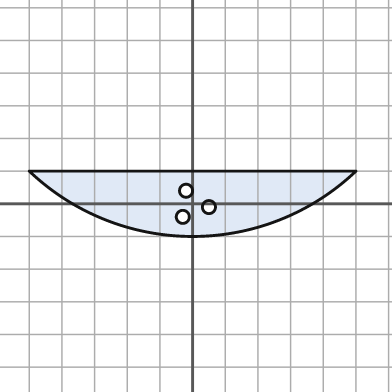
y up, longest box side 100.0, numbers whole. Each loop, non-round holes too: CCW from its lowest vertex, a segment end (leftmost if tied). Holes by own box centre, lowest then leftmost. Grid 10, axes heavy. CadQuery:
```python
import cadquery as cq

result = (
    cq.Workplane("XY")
    .moveTo(-50.0, 10.0)
    .threePointArc((0.0, -10.0), (50.0, 10.0))
    .close()
    .moveTo(-3.0, -4.0)
    .circle(2.0)
    .moveTo(5.0, -1.0)
    .circle(2.0)
    .moveTo(-2.0, 4.0)
    .circle(2.0)
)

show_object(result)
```